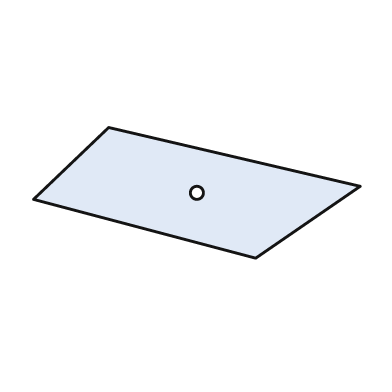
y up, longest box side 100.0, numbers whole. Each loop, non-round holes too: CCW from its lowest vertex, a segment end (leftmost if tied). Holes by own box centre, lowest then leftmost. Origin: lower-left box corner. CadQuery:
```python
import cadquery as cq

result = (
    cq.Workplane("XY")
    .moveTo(68.0, 0.0)
    .lineTo(100.0, 22.0)
    .lineTo(23.0, 40.0)
    .lineTo(0.0, 18.0)
    .close()
    .moveTo(50.0, 20.0)
    .circle(2.0)
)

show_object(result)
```